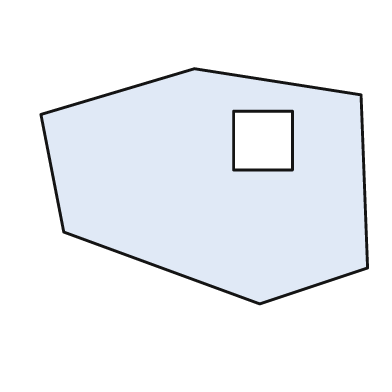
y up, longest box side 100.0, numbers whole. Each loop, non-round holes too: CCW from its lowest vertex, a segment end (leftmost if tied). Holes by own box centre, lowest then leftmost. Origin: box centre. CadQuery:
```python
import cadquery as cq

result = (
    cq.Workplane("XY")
    .moveTo(17.0, -36.0)
    .lineTo(50.0, -25.0)
    .lineTo(48.0, 28.0)
    .lineTo(-3.0, 36.0)
    .lineTo(-50.0, 22.0)
    .lineTo(-43.0, -14.0)
    .close()
    .moveTo(9.0, 5.0)
    .lineTo(27.0, 5.0)
    .lineTo(27.0, 23.0)
    .lineTo(9.0, 23.0)
    .close()
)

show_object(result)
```